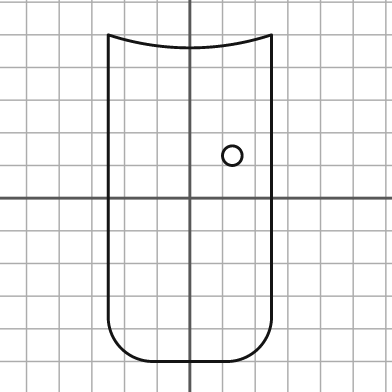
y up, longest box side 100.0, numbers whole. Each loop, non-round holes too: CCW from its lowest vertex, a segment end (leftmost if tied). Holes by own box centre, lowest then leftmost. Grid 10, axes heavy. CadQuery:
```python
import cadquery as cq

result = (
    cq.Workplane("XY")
    .moveTo(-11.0, -50.0)
    .lineTo(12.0, -50.0)
    .threePointArc((21.0, -46.0), (25.0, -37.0))
    .lineTo(25.0, 50.0)
    .threePointArc((0.0, 46.0), (-25.0, 50.0))
    .lineTo(-25.0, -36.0)
    .threePointArc((-21.0, -46.0), (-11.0, -50.0))
    .close()
    .moveTo(13.0, 13.0)
    .circle(3.0)
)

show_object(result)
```